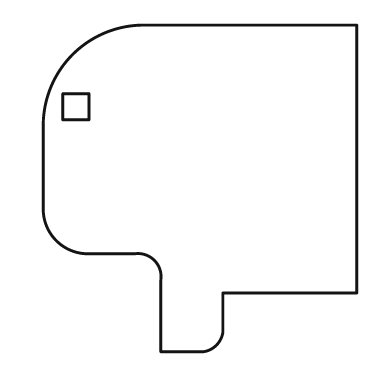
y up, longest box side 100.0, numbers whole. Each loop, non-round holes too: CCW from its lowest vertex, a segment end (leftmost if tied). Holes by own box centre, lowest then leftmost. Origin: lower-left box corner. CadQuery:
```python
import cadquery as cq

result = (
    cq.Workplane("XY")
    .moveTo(36.0, 0.0)
    .lineTo(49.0, 0.0)
    .threePointArc((53.0, 2.0), (55.0, 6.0))
    .lineTo(55.0, 18.0)
    .lineTo(96.0, 18.0)
    .lineTo(96.0, 100.0)
    .lineTo(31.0, 100.0)
    .threePointArc((9.0, 91.0), (0.0, 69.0))
    .lineTo(0.0, 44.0)
    .threePointArc((4.0, 34.0), (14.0, 30.0))
    .lineTo(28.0, 30.0)
    .threePointArc((34.0, 28.0), (36.0, 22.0))
    .close()
    .moveTo(6.0, 71.0)
    .lineTo(14.0, 71.0)
    .lineTo(14.0, 79.0)
    .lineTo(6.0, 79.0)
    .close()
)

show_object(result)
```